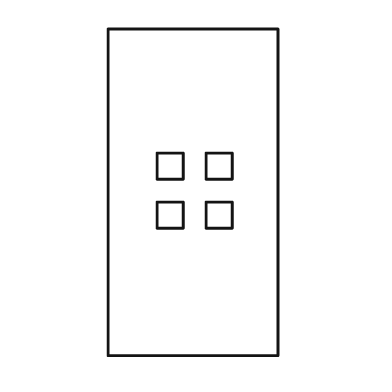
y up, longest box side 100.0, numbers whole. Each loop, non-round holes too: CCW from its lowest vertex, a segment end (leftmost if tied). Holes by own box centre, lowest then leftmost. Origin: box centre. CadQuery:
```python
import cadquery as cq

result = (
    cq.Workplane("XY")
    .moveTo(-26.0, -50.0)
    .lineTo(26.0, -50.0)
    .lineTo(26.0, 50.0)
    .lineTo(-26.0, 50.0)
    .close()
    .moveTo(-11.0, -11.0)
    .lineTo(-3.0, -11.0)
    .lineTo(-3.0, -3.0)
    .lineTo(-11.0, -3.0)
    .close()
    .moveTo(4.0, -11.0)
    .lineTo(12.0, -11.0)
    .lineTo(12.0, -3.0)
    .lineTo(4.0, -3.0)
    .close()
    .moveTo(-11.0, 4.0)
    .lineTo(-3.0, 4.0)
    .lineTo(-3.0, 12.0)
    .lineTo(-11.0, 12.0)
    .close()
    .moveTo(4.0, 4.0)
    .lineTo(12.0, 4.0)
    .lineTo(12.0, 12.0)
    .lineTo(4.0, 12.0)
    .close()
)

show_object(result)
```